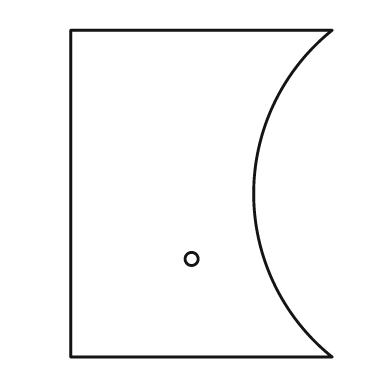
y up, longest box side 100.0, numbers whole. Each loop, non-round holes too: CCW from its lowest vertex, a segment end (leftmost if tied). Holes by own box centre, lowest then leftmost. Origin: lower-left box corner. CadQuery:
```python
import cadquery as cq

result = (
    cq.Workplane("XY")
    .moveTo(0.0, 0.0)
    .lineTo(80.0, 0.0)
    .threePointArc((56.0, 50.0), (80.0, 100.0))
    .lineTo(0.0, 100.0)
    .close()
    .moveTo(37.0, 30.0)
    .circle(2.0)
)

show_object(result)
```